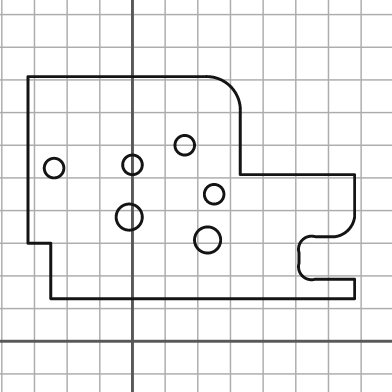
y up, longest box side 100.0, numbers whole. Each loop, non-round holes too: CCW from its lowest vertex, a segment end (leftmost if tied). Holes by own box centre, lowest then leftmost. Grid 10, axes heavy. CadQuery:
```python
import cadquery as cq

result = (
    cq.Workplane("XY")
    .moveTo(-25.0, 13.0)
    .lineTo(68.0, 13.0)
    .lineTo(68.0, 19.0)
    .lineTo(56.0, 19.0)
    .threePointArc((52.0, 20.0), (51.0, 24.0))
    .lineTo(51.0, 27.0)
    .threePointArc((52.0, 31.0), (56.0, 32.0))
    .lineTo(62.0, 32.0)
    .threePointArc((66.0, 34.0), (68.0, 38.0))
    .lineTo(68.0, 51.0)
    .lineTo(33.0, 51.0)
    .lineTo(33.0, 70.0)
    .threePointArc((30.0, 78.0), (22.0, 81.0))
    .lineTo(-32.0, 81.0)
    .lineTo(-32.0, 30.0)
    .lineTo(-25.0, 30.0)
    .close()
    .moveTo(23.0, 31.0)
    .circle(4.0)
    .moveTo(-1.0, 38.0)
    .circle(4.0)
    .moveTo(25.0, 45.0)
    .circle(3.0)
    .moveTo(-24.0, 53.0)
    .circle(3.0)
    .moveTo(0.0, 54.0)
    .circle(3.0)
    .moveTo(16.0, 60.0)
    .circle(3.0)
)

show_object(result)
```